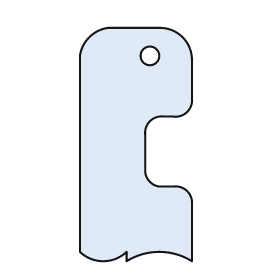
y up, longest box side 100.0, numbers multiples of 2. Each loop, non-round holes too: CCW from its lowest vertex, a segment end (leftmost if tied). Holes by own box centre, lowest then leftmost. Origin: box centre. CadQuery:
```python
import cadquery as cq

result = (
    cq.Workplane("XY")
    .moveTo(-4.0, -50.0)
    .threePointArc((10.0, -46.0), (24.0, -50.0))
    .lineTo(24.0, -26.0)
    .threePointArc((22.0, -20.0), (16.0, -18.0))
    .lineTo(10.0, -18.0)
    .threePointArc((6.0, -16.0), (4.0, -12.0))
    .lineTo(4.0, 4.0)
    .threePointArc((6.0, 10.0), (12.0, 12.0))
    .lineTo(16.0, 12.0)
    .threePointArc((22.0, 14.0), (24.0, 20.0))
    .lineTo(24.0, 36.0)
    .threePointArc((20.0, 46.0), (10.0, 50.0))
    .lineTo(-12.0, 50.0)
    .threePointArc((-20.0, 46.0), (-24.0, 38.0))
    .lineTo(-24.0, -46.0)
    .threePointArc((-14.0, -50.0), (-4.0, -46.0))
    .close()
    .moveTo(6.0, 38.0)
    .circle(4.0)
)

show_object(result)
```